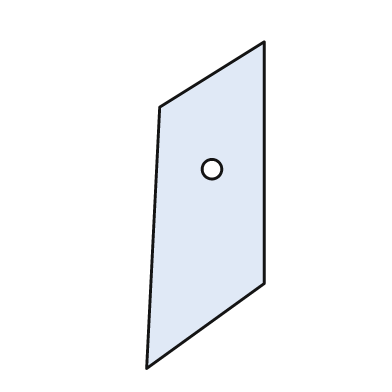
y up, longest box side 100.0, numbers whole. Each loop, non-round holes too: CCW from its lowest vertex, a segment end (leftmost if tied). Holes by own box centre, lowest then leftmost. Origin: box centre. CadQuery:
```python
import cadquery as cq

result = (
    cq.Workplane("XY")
    .moveTo(-18.0, -50.0)
    .lineTo(18.0, -24.0)
    .lineTo(18.0, 50.0)
    .lineTo(-14.0, 30.0)
    .close()
    .moveTo(2.0, 11.0)
    .circle(3.0)
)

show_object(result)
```